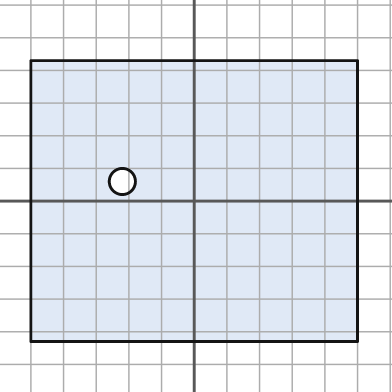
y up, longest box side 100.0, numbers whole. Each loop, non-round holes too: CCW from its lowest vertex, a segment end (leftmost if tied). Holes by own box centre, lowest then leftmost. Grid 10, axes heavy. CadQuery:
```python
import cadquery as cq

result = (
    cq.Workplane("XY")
    .moveTo(-50.0, -43.0)
    .lineTo(50.0, -43.0)
    .lineTo(50.0, 43.0)
    .lineTo(-50.0, 43.0)
    .close()
    .moveTo(-22.0, 6.0)
    .circle(4.0)
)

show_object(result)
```